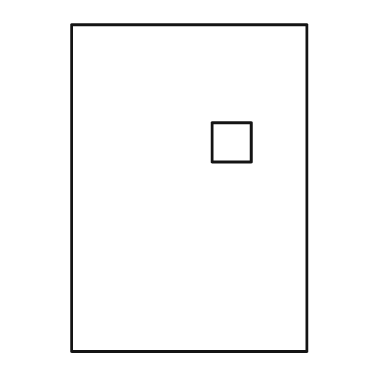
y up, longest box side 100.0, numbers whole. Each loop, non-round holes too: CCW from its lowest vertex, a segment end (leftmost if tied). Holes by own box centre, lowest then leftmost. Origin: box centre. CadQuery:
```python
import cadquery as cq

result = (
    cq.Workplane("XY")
    .moveTo(-36.0, -50.0)
    .lineTo(36.0, -50.0)
    .lineTo(36.0, 50.0)
    .lineTo(-36.0, 50.0)
    .close()
    .moveTo(7.0, 8.0)
    .lineTo(19.0, 8.0)
    .lineTo(19.0, 20.0)
    .lineTo(7.0, 20.0)
    .close()
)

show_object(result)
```